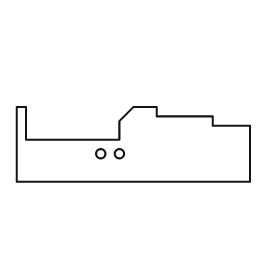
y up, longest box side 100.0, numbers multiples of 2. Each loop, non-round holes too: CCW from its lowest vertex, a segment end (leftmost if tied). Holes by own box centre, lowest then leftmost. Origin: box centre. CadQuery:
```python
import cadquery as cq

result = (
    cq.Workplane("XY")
    .moveTo(-50.0, -16.0)
    .lineTo(50.0, -16.0)
    .lineTo(50.0, 8.0)
    .lineTo(34.0, 8.0)
    .lineTo(34.0, 12.0)
    .lineTo(10.0, 12.0)
    .lineTo(10.0, 16.0)
    .lineTo(0.0, 16.0)
    .lineTo(-6.0, 10.0)
    .lineTo(-6.0, 2.0)
    .lineTo(-46.0, 2.0)
    .lineTo(-46.0, 16.0)
    .lineTo(-50.0, 16.0)
    .close()
    .moveTo(-14.0, -4.0)
    .circle(2.0)
    .moveTo(-6.0, -4.0)
    .circle(2.0)
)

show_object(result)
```